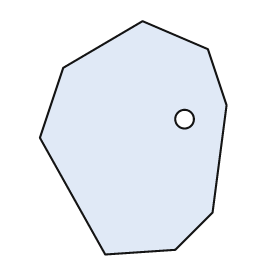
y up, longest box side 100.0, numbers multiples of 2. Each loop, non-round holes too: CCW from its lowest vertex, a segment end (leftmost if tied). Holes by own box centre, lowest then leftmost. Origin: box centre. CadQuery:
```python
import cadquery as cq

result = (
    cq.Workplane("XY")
    .moveTo(-12.0, -50.0)
    .lineTo(18.0, -48.0)
    .lineTo(34.0, -32.0)
    .lineTo(40.0, 14.0)
    .lineTo(32.0, 38.0)
    .lineTo(4.0, 50.0)
    .lineTo(-30.0, 30.0)
    .lineTo(-40.0, 0.0)
    .close()
    .moveTo(22.0, 8.0)
    .circle(4.0)
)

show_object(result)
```